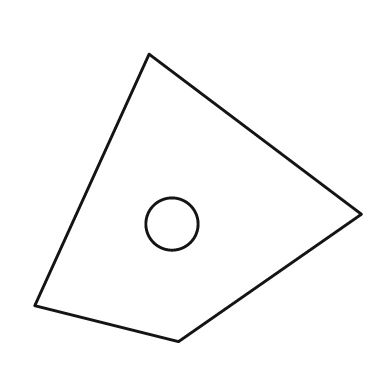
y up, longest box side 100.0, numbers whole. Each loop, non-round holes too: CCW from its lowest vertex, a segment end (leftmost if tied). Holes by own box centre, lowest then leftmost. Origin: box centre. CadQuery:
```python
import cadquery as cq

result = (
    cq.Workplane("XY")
    .moveTo(-6.0, -44.0)
    .lineTo(50.0, -5.0)
    .lineTo(-15.0, 44.0)
    .lineTo(-50.0, -33.0)
    .close()
    .moveTo(-8.0, -8.0)
    .circle(8.0)
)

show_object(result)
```